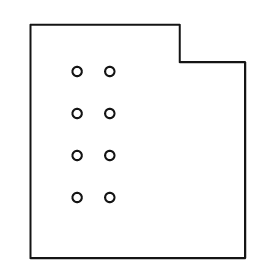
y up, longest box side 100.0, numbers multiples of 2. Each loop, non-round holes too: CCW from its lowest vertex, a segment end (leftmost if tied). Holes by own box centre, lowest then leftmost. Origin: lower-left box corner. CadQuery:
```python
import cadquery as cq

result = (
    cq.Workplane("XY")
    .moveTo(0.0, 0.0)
    .lineTo(92.0, 0.0)
    .lineTo(92.0, 84.0)
    .lineTo(64.0, 84.0)
    .lineTo(64.0, 100.0)
    .lineTo(0.0, 100.0)
    .close()
    .moveTo(20.0, 26.0)
    .circle(2.0)
    .moveTo(34.0, 26.0)
    .circle(2.0)
    .moveTo(20.0, 44.0)
    .circle(2.0)
    .moveTo(34.0, 44.0)
    .circle(2.0)
    .moveTo(20.0, 62.0)
    .circle(2.0)
    .moveTo(34.0, 62.0)
    .circle(2.0)
    .moveTo(20.0, 80.0)
    .circle(2.0)
    .moveTo(34.0, 80.0)
    .circle(2.0)
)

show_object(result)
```